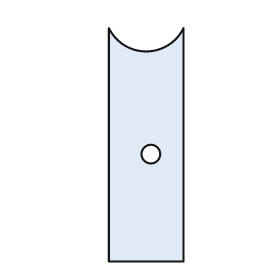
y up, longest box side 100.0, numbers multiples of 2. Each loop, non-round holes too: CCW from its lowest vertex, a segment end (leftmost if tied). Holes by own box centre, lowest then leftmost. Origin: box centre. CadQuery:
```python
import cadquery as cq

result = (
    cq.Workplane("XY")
    .moveTo(-16.0, -50.0)
    .lineTo(16.0, -50.0)
    .lineTo(16.0, 50.0)
    .threePointArc((0.0, 40.0), (-16.0, 50.0))
    .close()
    .moveTo(2.0, -4.0)
    .circle(4.0)
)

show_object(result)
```